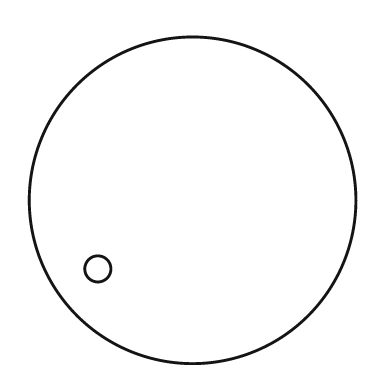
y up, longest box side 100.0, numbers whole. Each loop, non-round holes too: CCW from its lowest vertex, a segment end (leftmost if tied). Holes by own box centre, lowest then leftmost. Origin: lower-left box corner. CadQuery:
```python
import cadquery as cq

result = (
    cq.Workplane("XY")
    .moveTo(50.0, 50.0)
    .circle(50.0)
    .moveTo(21.0, 29.0)
    .circle(4.0)
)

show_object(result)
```